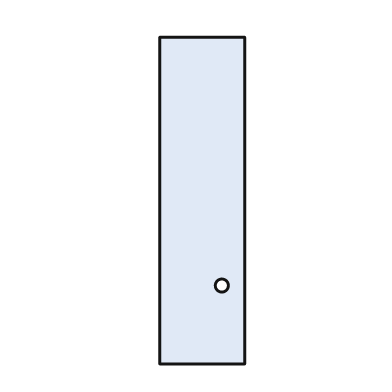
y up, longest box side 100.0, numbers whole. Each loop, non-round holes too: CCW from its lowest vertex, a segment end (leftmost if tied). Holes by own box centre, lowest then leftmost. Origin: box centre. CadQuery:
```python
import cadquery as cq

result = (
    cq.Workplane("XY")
    .moveTo(-13.0, -50.0)
    .lineTo(13.0, -50.0)
    .lineTo(13.0, 50.0)
    .lineTo(-13.0, 50.0)
    .close()
    .moveTo(6.0, -26.0)
    .circle(2.0)
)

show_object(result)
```